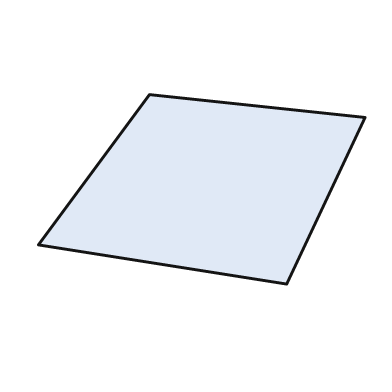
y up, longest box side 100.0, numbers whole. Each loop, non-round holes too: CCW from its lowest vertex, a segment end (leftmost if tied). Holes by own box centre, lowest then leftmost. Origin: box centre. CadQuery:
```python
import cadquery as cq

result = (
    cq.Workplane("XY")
    .moveTo(26.0, -29.0)
    .lineTo(50.0, 22.0)
    .lineTo(-16.0, 29.0)
    .lineTo(-50.0, -17.0)
    .close()
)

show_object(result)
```